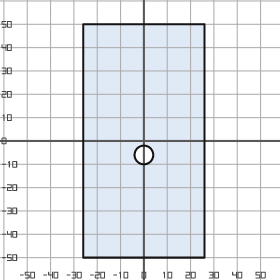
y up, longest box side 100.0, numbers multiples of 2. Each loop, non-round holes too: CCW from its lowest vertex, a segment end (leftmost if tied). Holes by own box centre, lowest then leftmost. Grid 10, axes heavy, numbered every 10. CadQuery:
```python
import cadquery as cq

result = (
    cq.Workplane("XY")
    .moveTo(-26.0, -50.0)
    .lineTo(26.0, -50.0)
    .lineTo(26.0, 50.0)
    .lineTo(-26.0, 50.0)
    .close()
    .moveTo(0.0, -6.0)
    .circle(4.0)
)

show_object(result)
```